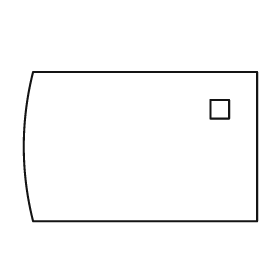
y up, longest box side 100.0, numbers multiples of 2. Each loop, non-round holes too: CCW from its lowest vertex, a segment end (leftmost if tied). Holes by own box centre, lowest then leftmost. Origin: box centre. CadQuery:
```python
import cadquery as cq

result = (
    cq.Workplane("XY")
    .moveTo(-46.0, -32.0)
    .lineTo(50.0, -32.0)
    .lineTo(50.0, 32.0)
    .lineTo(-46.0, 32.0)
    .threePointArc((-50.0, 0.0), (-46.0, -32.0))
    .close()
    .moveTo(30.0, 12.0)
    .lineTo(38.0, 12.0)
    .lineTo(38.0, 20.0)
    .lineTo(30.0, 20.0)
    .close()
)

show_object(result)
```